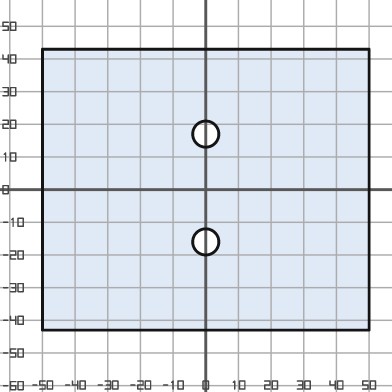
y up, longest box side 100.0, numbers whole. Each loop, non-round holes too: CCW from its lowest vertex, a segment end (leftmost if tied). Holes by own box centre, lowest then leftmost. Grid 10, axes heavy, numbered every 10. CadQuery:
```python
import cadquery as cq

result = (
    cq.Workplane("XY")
    .moveTo(-50.0, -43.0)
    .lineTo(50.0, -43.0)
    .lineTo(50.0, 43.0)
    .lineTo(-50.0, 43.0)
    .close()
    .moveTo(0.0, -16.0)
    .circle(4.0)
    .moveTo(0.0, 17.0)
    .circle(4.0)
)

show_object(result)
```